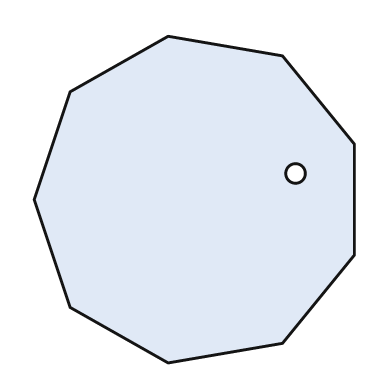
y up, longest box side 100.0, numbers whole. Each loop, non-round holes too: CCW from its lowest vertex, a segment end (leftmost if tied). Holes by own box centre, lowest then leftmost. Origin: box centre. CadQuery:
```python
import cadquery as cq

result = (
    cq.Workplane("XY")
    .moveTo(-8.0, -50.0)
    .lineTo(27.0, -44.0)
    .lineTo(49.0, -17.0)
    .lineTo(49.0, 17.0)
    .lineTo(27.0, 44.0)
    .lineTo(-8.0, 50.0)
    .lineTo(-38.0, 33.0)
    .lineTo(-49.0, 0.0)
    .lineTo(-38.0, -33.0)
    .close()
    .moveTo(31.0, 8.0)
    .circle(3.0)
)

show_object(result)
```